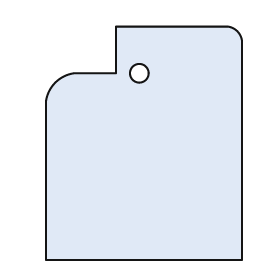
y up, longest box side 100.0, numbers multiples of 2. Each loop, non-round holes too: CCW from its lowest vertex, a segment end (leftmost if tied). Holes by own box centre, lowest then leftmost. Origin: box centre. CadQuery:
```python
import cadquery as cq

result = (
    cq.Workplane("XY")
    .moveTo(-42.0, -50.0)
    .lineTo(42.0, -50.0)
    .lineTo(42.0, 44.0)
    .threePointArc((40.0, 48.0), (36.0, 50.0))
    .lineTo(-12.0, 50.0)
    .lineTo(-12.0, 30.0)
    .lineTo(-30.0, 30.0)
    .threePointArc((-38.0, 26.0), (-42.0, 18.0))
    .close()
    .moveTo(-2.0, 30.0)
    .circle(4.0)
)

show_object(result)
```